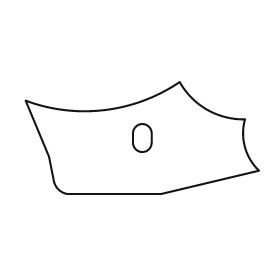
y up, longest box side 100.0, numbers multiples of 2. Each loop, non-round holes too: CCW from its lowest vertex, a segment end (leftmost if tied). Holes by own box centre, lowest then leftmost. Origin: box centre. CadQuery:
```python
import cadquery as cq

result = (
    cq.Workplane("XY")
    .moveTo(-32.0, -24.0)
    .lineTo(8.0, -24.0)
    .lineTo(50.0, -14.0)
    .threePointArc((44.0, -4.0), (44.0, 8.0))
    .threePointArc((28.0, 12.0), (16.0, 24.0))
    .threePointArc((-16.0, 12.0), (-50.0, 16.0))
    .lineTo(-40.0, -8.0)
    .lineTo(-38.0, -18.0)
    .threePointArc((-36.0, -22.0), (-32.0, -24.0))
    .close()
    .moveTo(-4.0, -2.0)
    .threePointArc((0.0, -6.0), (4.0, -2.0))
    .lineTo(4.0, 2.0)
    .threePointArc((0.0, 6.0), (-4.0, 2.0))
    .close()
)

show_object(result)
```